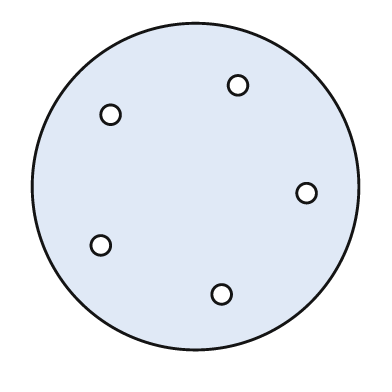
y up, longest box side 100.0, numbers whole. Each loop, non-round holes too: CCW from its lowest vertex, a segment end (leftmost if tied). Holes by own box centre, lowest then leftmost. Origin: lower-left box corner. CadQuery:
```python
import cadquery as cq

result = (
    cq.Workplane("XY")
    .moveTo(50.0, 50.0)
    .circle(50.0)
    .moveTo(58.0, 17.0)
    .circle(3.0)
    .moveTo(21.0, 32.0)
    .circle(3.0)
    .moveTo(84.0, 48.0)
    .circle(3.0)
    .moveTo(24.0, 72.0)
    .circle(3.0)
    .moveTo(63.0, 81.0)
    .circle(3.0)
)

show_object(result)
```